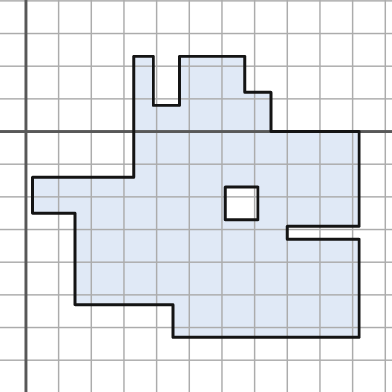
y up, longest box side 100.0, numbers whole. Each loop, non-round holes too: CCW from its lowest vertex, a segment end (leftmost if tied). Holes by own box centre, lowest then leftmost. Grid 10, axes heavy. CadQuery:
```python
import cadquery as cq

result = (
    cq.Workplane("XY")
    .moveTo(45.0, -63.0)
    .lineTo(102.0, -63.0)
    .lineTo(102.0, -33.0)
    .lineTo(80.0, -33.0)
    .lineTo(80.0, -29.0)
    .lineTo(102.0, -29.0)
    .lineTo(102.0, 0.0)
    .lineTo(75.0, 0.0)
    .lineTo(75.0, 12.0)
    .lineTo(67.0, 12.0)
    .lineTo(67.0, 23.0)
    .lineTo(47.0, 23.0)
    .lineTo(47.0, 8.0)
    .lineTo(39.0, 8.0)
    .lineTo(39.0, 23.0)
    .lineTo(33.0, 23.0)
    .lineTo(33.0, -14.0)
    .lineTo(2.0, -14.0)
    .lineTo(2.0, -25.0)
    .lineTo(15.0, -25.0)
    .lineTo(15.0, -53.0)
    .lineTo(45.0, -53.0)
    .close()
    .moveTo(61.0, -27.0)
    .lineTo(71.0, -27.0)
    .lineTo(71.0, -17.0)
    .lineTo(61.0, -17.0)
    .close()
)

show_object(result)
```